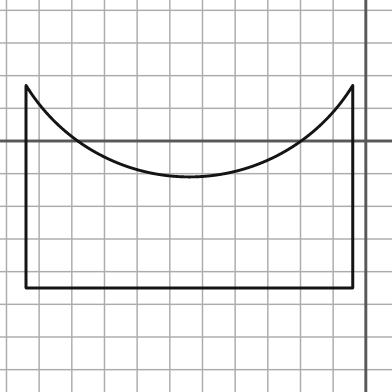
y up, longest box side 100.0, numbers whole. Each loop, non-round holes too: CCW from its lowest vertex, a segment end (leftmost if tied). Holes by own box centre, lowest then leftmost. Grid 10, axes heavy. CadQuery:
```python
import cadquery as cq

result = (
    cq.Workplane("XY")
    .moveTo(-104.0, -45.0)
    .lineTo(-4.0, -45.0)
    .lineTo(-4.0, 17.0)
    .threePointArc((-54.0, -11.0), (-104.0, 17.0))
    .close()
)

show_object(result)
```